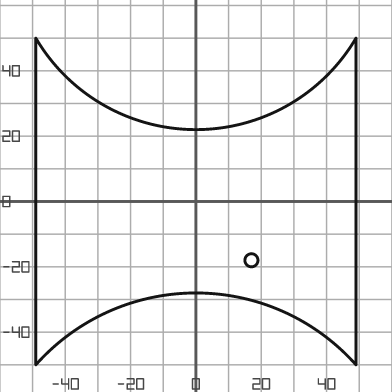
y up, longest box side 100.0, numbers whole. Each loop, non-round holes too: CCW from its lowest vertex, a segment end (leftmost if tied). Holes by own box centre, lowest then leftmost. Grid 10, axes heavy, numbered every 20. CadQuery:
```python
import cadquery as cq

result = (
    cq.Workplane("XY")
    .moveTo(-49.0, -50.0)
    .threePointArc((0.0, -28.0), (49.0, -50.0))
    .lineTo(49.0, 50.0)
    .threePointArc((0.0, 22.0), (-49.0, 50.0))
    .close()
    .moveTo(17.0, -18.0)
    .circle(2.0)
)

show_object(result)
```